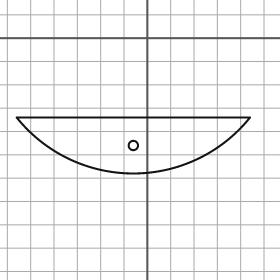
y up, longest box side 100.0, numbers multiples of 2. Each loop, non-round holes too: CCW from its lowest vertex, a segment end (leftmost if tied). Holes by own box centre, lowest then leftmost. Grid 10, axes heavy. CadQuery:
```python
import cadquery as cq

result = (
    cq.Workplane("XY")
    .moveTo(-56.0, -34.0)
    .threePointArc((-6.0, -58.0), (44.0, -34.0))
    .close()
    .moveTo(-6.0, -46.0)
    .circle(2.0)
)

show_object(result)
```